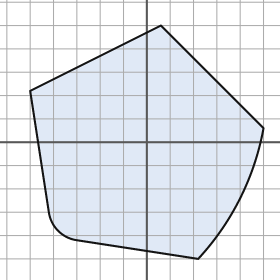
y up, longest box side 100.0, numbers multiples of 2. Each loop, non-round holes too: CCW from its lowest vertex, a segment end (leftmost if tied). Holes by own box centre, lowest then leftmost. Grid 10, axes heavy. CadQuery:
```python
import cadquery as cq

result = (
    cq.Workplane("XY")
    .moveTo(22.0, -50.0)
    .threePointArc((40.0, -24.0), (50.0, 6.0))
    .lineTo(6.0, 50.0)
    .lineTo(-50.0, 22.0)
    .lineTo(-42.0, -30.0)
    .threePointArc((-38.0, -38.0), (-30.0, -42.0))
    .close()
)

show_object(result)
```